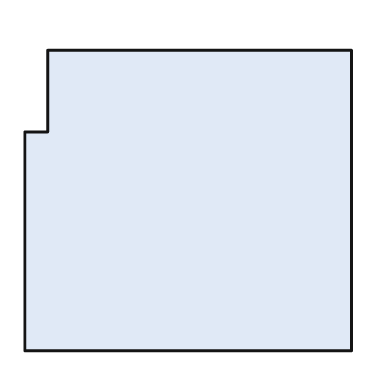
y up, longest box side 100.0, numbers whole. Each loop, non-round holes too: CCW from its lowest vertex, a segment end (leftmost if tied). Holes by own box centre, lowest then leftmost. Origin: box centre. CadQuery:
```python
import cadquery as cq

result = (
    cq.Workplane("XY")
    .moveTo(-50.0, -46.0)
    .lineTo(50.0, -46.0)
    .lineTo(50.0, 46.0)
    .lineTo(-43.0, 46.0)
    .lineTo(-43.0, 21.0)
    .lineTo(-50.0, 21.0)
    .close()
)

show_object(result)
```